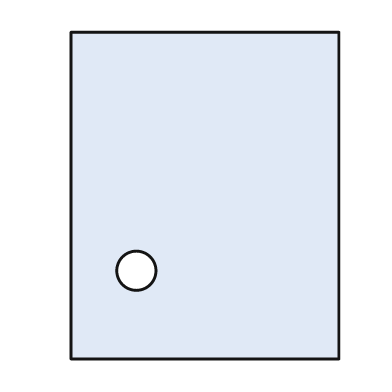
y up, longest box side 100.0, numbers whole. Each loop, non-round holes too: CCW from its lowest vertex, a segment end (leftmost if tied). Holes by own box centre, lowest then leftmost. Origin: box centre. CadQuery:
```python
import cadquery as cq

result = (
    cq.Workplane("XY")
    .moveTo(-41.0, -50.0)
    .lineTo(41.0, -50.0)
    .lineTo(41.0, 50.0)
    .lineTo(-41.0, 50.0)
    .close()
    .moveTo(-21.0, -23.0)
    .circle(6.0)
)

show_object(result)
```